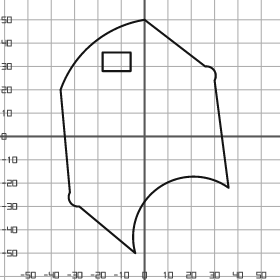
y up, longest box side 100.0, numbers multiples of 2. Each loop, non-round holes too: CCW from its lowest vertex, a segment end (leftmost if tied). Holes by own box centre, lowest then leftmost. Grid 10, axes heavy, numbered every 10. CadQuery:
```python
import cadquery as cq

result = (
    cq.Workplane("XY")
    .moveTo(-4.0, -50.0)
    .threePointArc((6.0, -22.0), (36.0, -22.0))
    .lineTo(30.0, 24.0)
    .threePointArc((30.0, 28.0), (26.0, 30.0))
    .lineTo(0.0, 50.0)
    .threePointArc((-22.0, 40.0), (-36.0, 20.0))
    .lineTo(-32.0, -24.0)
    .threePointArc((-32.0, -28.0), (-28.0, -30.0))
    .close()
    .moveTo(-18.0, 28.0)
    .lineTo(-6.0, 28.0)
    .lineTo(-6.0, 36.0)
    .lineTo(-18.0, 36.0)
    .close()
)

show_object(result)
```